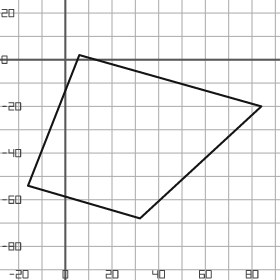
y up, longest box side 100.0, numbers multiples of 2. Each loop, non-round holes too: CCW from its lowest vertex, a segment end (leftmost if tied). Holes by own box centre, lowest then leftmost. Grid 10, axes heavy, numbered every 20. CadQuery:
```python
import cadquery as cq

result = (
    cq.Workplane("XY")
    .moveTo(32.0, -68.0)
    .lineTo(84.0, -20.0)
    .lineTo(6.0, 2.0)
    .lineTo(-16.0, -54.0)
    .close()
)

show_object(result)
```